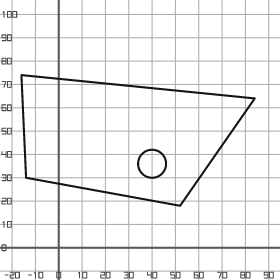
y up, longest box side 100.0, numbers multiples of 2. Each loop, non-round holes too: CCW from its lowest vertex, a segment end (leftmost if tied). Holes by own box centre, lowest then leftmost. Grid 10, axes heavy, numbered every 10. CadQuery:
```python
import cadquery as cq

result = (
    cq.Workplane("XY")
    .moveTo(52.0, 18.0)
    .lineTo(84.0, 64.0)
    .lineTo(-16.0, 74.0)
    .lineTo(-14.0, 30.0)
    .close()
    .moveTo(40.0, 36.0)
    .circle(6.0)
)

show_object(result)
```